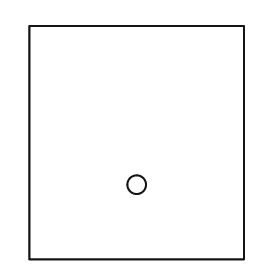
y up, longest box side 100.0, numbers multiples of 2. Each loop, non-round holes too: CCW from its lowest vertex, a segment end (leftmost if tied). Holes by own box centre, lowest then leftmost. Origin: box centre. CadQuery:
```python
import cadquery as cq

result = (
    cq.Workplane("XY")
    .moveTo(-46.0, -50.0)
    .lineTo(46.0, -50.0)
    .lineTo(46.0, 50.0)
    .lineTo(-46.0, 50.0)
    .close()
    .moveTo(0.0, -18.0)
    .circle(4.0)
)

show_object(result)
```